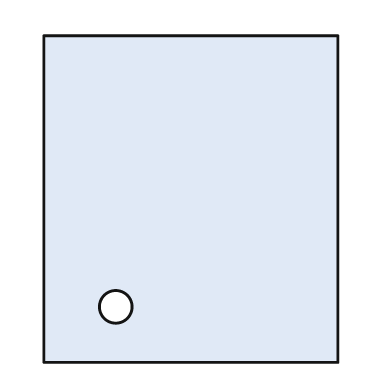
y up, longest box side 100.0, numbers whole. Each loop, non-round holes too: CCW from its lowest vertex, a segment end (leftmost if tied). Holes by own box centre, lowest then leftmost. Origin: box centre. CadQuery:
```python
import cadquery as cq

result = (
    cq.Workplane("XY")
    .moveTo(-45.0, -50.0)
    .lineTo(45.0, -50.0)
    .lineTo(45.0, 50.0)
    .lineTo(-45.0, 50.0)
    .close()
    .moveTo(-23.0, -33.0)
    .circle(5.0)
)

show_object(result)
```